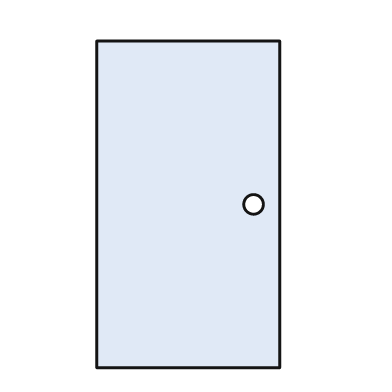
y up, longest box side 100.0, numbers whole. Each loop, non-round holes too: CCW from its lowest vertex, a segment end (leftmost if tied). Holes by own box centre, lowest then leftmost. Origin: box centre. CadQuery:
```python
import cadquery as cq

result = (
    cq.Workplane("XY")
    .moveTo(-28.0, -50.0)
    .lineTo(28.0, -50.0)
    .lineTo(28.0, 50.0)
    .lineTo(-28.0, 50.0)
    .close()
    .moveTo(20.0, 0.0)
    .circle(3.0)
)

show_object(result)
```